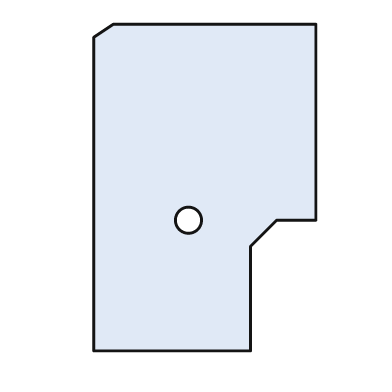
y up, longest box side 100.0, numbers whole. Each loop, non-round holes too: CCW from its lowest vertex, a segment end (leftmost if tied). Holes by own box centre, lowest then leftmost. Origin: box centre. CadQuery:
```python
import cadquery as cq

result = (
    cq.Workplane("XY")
    .moveTo(-34.0, -50.0)
    .lineTo(14.0, -50.0)
    .lineTo(14.0, -18.0)
    .lineTo(22.0, -10.0)
    .lineTo(34.0, -10.0)
    .lineTo(34.0, 50.0)
    .lineTo(-28.0, 50.0)
    .lineTo(-34.0, 46.0)
    .close()
    .moveTo(-5.0, -10.0)
    .circle(4.0)
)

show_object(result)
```